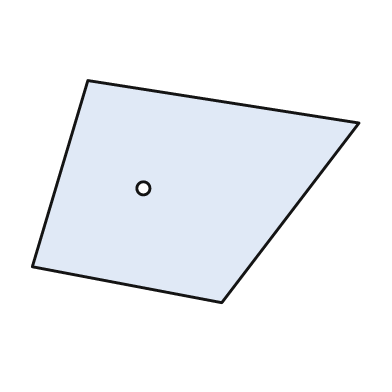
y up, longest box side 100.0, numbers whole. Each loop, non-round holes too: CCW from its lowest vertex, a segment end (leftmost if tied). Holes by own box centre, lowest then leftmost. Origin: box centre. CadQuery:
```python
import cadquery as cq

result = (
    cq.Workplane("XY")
    .moveTo(8.0, -34.0)
    .lineTo(50.0, 21.0)
    .lineTo(-33.0, 34.0)
    .lineTo(-50.0, -23.0)
    .close()
    .moveTo(-16.0, 1.0)
    .circle(2.0)
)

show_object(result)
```